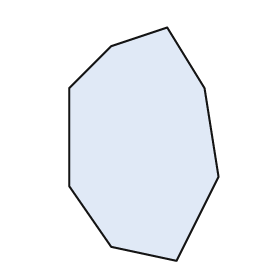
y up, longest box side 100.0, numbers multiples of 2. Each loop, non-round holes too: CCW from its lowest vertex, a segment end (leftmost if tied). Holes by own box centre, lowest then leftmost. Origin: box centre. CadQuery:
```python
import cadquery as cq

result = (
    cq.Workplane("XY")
    .moveTo(14.0, -50.0)
    .lineTo(32.0, -14.0)
    .lineTo(26.0, 24.0)
    .lineTo(10.0, 50.0)
    .lineTo(-14.0, 42.0)
    .lineTo(-32.0, 24.0)
    .lineTo(-32.0, -18.0)
    .lineTo(-14.0, -44.0)
    .close()
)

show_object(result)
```